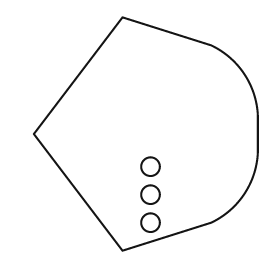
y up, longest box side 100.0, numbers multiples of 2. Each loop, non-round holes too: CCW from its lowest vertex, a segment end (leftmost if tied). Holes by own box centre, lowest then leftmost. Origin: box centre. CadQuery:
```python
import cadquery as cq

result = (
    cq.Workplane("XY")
    .moveTo(-10.0, -50.0)
    .lineTo(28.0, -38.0)
    .threePointArc((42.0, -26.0), (48.0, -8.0))
    .lineTo(48.0, 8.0)
    .threePointArc((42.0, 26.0), (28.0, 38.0))
    .lineTo(-10.0, 50.0)
    .lineTo(-48.0, 0.0)
    .close()
    .moveTo(2.0, -38.0)
    .circle(4.0)
    .moveTo(2.0, -26.0)
    .circle(4.0)
    .moveTo(2.0, -14.0)
    .circle(4.0)
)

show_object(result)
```